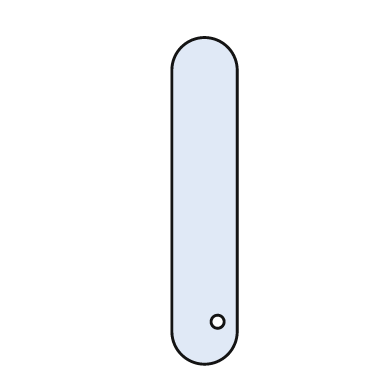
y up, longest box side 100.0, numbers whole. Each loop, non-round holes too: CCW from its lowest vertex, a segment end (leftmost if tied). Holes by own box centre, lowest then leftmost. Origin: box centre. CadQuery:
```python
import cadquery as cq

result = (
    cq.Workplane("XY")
    .moveTo(-10.0, -40.0)
    .threePointArc((0.0, -50.0), (10.0, -40.0))
    .lineTo(10.0, 40.0)
    .threePointArc((0.0, 50.0), (-10.0, 40.0))
    .close()
    .moveTo(4.0, -37.0)
    .circle(2.0)
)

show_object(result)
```